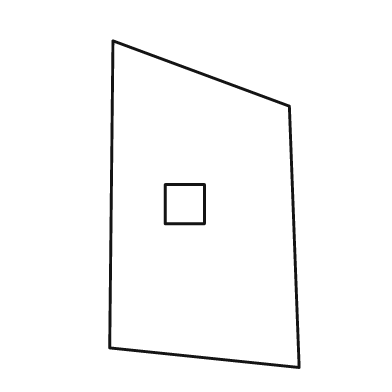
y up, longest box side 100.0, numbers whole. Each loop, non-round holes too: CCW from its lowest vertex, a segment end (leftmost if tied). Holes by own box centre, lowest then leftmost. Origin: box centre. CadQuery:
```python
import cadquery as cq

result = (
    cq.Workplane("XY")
    .moveTo(29.0, -50.0)
    .lineTo(26.0, 30.0)
    .lineTo(-28.0, 50.0)
    .lineTo(-29.0, -44.0)
    .close()
    .moveTo(-12.0, -6.0)
    .lineTo(0.0, -6.0)
    .lineTo(0.0, 6.0)
    .lineTo(-12.0, 6.0)
    .close()
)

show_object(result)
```